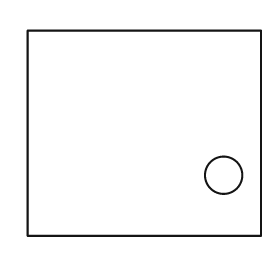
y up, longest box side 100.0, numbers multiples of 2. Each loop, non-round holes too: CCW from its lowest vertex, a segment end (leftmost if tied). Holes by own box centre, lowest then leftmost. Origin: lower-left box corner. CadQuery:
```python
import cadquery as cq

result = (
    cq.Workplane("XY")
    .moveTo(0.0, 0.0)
    .lineTo(100.0, 0.0)
    .lineTo(100.0, 88.0)
    .lineTo(0.0, 88.0)
    .close()
    .moveTo(84.0, 26.0)
    .circle(8.0)
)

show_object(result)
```